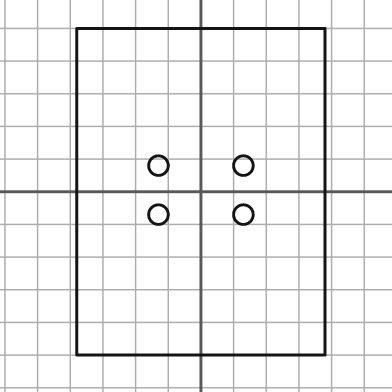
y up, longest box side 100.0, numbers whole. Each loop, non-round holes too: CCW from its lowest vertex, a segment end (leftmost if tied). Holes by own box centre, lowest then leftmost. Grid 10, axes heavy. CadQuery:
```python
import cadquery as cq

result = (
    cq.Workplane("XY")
    .moveTo(-38.0, -50.0)
    .lineTo(38.0, -50.0)
    .lineTo(38.0, 50.0)
    .lineTo(-38.0, 50.0)
    .close()
    .moveTo(-13.0, -7.0)
    .circle(3.0)
    .moveTo(13.0, -7.0)
    .circle(3.0)
    .moveTo(-13.0, 8.0)
    .circle(3.0)
    .moveTo(13.0, 8.0)
    .circle(3.0)
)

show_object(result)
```